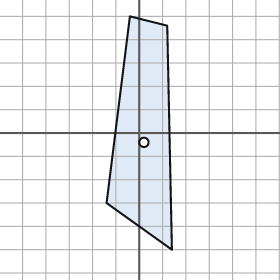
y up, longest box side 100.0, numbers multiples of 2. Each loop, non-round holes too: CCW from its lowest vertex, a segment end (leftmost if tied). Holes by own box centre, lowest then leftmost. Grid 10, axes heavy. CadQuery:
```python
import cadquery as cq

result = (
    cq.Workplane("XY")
    .moveTo(14.0, -50.0)
    .lineTo(12.0, 46.0)
    .lineTo(-4.0, 50.0)
    .lineTo(-14.0, -30.0)
    .close()
    .moveTo(2.0, -4.0)
    .circle(2.0)
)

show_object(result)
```